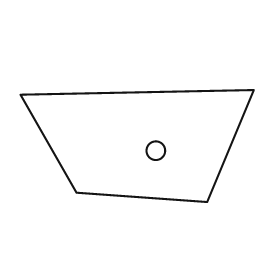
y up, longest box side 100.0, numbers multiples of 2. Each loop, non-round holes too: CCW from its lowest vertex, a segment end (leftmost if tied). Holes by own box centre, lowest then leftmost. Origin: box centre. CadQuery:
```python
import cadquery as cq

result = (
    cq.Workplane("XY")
    .moveTo(30.0, -24.0)
    .lineTo(50.0, 24.0)
    .lineTo(-50.0, 22.0)
    .lineTo(-26.0, -20.0)
    .close()
    .moveTo(8.0, -2.0)
    .circle(4.0)
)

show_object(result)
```